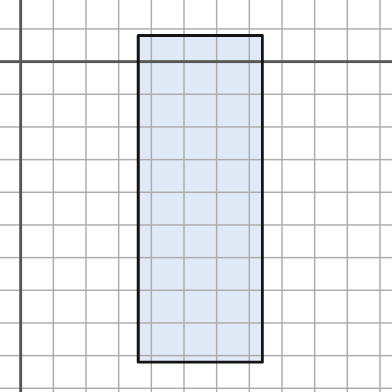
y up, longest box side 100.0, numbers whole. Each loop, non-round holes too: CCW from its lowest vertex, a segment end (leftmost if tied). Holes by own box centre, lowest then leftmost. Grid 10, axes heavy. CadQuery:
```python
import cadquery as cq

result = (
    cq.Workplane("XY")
    .moveTo(36.0, -92.0)
    .lineTo(74.0, -92.0)
    .lineTo(74.0, 8.0)
    .lineTo(36.0, 8.0)
    .close()
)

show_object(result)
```